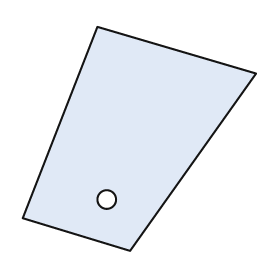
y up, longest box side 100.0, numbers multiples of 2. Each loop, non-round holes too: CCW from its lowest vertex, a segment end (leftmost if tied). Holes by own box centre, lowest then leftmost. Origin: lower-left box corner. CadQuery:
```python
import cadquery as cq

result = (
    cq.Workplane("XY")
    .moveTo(46.0, 0.0)
    .lineTo(100.0, 76.0)
    .lineTo(32.0, 96.0)
    .lineTo(0.0, 14.0)
    .close()
    .moveTo(36.0, 22.0)
    .circle(4.0)
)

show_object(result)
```